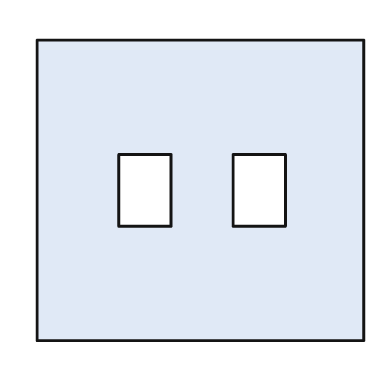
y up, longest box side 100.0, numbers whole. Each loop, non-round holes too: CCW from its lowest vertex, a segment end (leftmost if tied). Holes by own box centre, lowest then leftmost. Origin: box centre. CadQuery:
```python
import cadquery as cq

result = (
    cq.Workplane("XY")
    .moveTo(-50.0, -46.0)
    .lineTo(50.0, -46.0)
    .lineTo(50.0, 46.0)
    .lineTo(-50.0, 46.0)
    .close()
    .moveTo(-25.0, -11.0)
    .lineTo(-9.0, -11.0)
    .lineTo(-9.0, 11.0)
    .lineTo(-25.0, 11.0)
    .close()
    .moveTo(10.0, -11.0)
    .lineTo(26.0, -11.0)
    .lineTo(26.0, 11.0)
    .lineTo(10.0, 11.0)
    .close()
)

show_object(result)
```